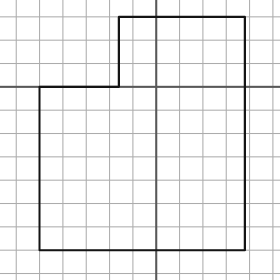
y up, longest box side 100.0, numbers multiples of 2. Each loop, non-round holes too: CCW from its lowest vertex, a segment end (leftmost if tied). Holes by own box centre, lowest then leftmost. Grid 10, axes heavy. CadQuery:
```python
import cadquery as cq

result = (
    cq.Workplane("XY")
    .moveTo(-50.0, -70.0)
    .lineTo(38.0, -70.0)
    .lineTo(38.0, 30.0)
    .lineTo(-16.0, 30.0)
    .lineTo(-16.0, 0.0)
    .lineTo(-50.0, 0.0)
    .close()
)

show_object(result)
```